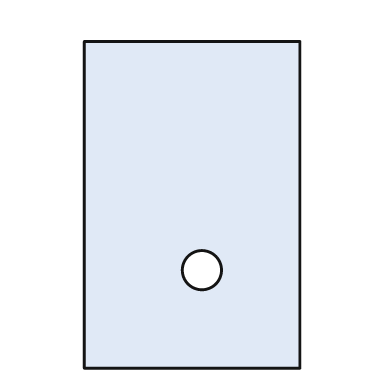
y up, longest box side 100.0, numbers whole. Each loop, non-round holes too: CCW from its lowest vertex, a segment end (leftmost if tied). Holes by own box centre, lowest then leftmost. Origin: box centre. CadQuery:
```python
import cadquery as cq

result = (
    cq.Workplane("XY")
    .moveTo(-33.0, -50.0)
    .lineTo(33.0, -50.0)
    .lineTo(33.0, 50.0)
    .lineTo(-33.0, 50.0)
    .close()
    .moveTo(3.0, -20.0)
    .circle(6.0)
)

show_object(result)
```